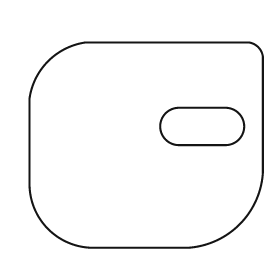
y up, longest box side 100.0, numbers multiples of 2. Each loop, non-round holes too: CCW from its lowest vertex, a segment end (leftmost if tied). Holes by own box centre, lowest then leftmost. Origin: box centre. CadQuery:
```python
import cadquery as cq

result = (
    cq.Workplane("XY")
    .moveTo(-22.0, -44.0)
    .lineTo(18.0, -44.0)
    .threePointArc((40.0, -34.0), (50.0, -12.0))
    .lineTo(50.0, 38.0)
    .threePointArc((48.0, 42.0), (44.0, 44.0))
    .lineTo(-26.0, 44.0)
    .threePointArc((-42.0, 36.0), (-50.0, 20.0))
    .lineTo(-50.0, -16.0)
    .threePointArc((-42.0, -36.0), (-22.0, -44.0))
    .close()
    .moveTo(14.0, 0.0)
    .lineTo(34.0, 0.0)
    .threePointArc((42.0, 8.0), (34.0, 16.0))
    .lineTo(14.0, 16.0)
    .threePointArc((6.0, 8.0), (14.0, 0.0))
    .close()
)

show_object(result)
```